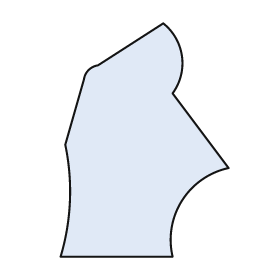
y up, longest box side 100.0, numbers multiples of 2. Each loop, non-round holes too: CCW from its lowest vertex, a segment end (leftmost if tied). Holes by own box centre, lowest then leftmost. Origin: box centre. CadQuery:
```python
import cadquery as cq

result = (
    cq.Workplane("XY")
    .moveTo(-36.0, -50.0)
    .lineTo(12.0, -50.0)
    .threePointArc((16.0, -26.0), (36.0, -12.0))
    .lineTo(12.0, 20.0)
    .threePointArc((16.0, 36.0), (8.0, 50.0))
    .lineTo(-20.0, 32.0)
    .threePointArc((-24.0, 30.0), (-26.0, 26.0))
    .lineTo(-34.0, -2.0)
    .threePointArc((-32.0, -26.0), (-36.0, -50.0))
    .close()
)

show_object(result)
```